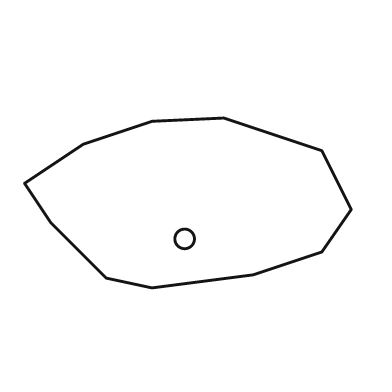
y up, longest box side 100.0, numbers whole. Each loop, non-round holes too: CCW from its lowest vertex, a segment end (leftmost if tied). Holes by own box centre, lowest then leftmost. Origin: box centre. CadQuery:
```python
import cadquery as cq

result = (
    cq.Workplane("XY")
    .moveTo(-11.0, -26.0)
    .lineTo(20.0, -22.0)
    .lineTo(41.0, -15.0)
    .lineTo(50.0, -2.0)
    .lineTo(41.0, 16.0)
    .lineTo(11.0, 26.0)
    .lineTo(-11.0, 25.0)
    .lineTo(-32.0, 18.0)
    .lineTo(-50.0, 6.0)
    .lineTo(-42.0, -6.0)
    .lineTo(-25.0, -23.0)
    .close()
    .moveTo(-1.0, -11.0)
    .circle(3.0)
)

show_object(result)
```